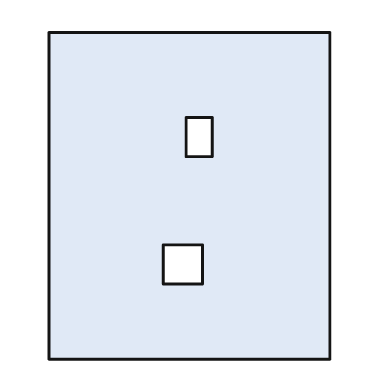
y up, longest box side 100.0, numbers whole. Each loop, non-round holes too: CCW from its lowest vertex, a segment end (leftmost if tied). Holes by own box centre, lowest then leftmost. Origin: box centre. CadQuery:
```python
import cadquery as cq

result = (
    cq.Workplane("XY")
    .moveTo(-43.0, -50.0)
    .lineTo(43.0, -50.0)
    .lineTo(43.0, 50.0)
    .lineTo(-43.0, 50.0)
    .close()
    .moveTo(-8.0, -27.0)
    .lineTo(4.0, -27.0)
    .lineTo(4.0, -15.0)
    .lineTo(-8.0, -15.0)
    .close()
    .moveTo(-1.0, 12.0)
    .lineTo(7.0, 12.0)
    .lineTo(7.0, 24.0)
    .lineTo(-1.0, 24.0)
    .close()
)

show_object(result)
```